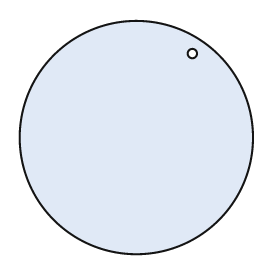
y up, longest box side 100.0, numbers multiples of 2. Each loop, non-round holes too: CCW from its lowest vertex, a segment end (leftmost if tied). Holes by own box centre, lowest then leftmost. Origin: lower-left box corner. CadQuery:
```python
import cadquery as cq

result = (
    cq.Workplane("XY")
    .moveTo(50.0, 50.0)
    .circle(50.0)
    .moveTo(74.0, 86.0)
    .circle(2.0)
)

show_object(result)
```